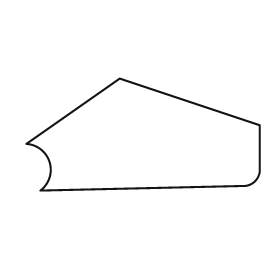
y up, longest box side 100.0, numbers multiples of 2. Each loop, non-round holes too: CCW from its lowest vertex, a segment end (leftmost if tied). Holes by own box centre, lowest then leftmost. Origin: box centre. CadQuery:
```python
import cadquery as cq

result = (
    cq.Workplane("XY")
    .moveTo(-44.0, -24.0)
    .lineTo(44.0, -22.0)
    .threePointArc((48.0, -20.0), (50.0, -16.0))
    .lineTo(50.0, 4.0)
    .lineTo(-10.0, 24.0)
    .lineTo(-50.0, -4.0)
    .threePointArc((-40.0, -12.0), (-44.0, -24.0))
    .close()
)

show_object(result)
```